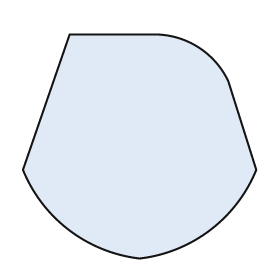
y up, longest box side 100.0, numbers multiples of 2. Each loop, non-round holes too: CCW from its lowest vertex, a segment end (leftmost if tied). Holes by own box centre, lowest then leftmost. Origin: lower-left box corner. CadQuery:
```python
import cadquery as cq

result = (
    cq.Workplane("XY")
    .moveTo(50.0, 0.0)
    .threePointArc((80.0, 12.0), (100.0, 38.0))
    .lineTo(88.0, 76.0)
    .threePointArc((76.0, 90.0), (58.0, 96.0))
    .lineTo(20.0, 96.0)
    .lineTo(0.0, 38.0)
    .threePointArc((20.0, 12.0), (50.0, 0.0))
    .close()
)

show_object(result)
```